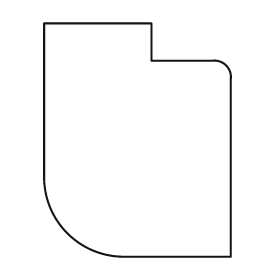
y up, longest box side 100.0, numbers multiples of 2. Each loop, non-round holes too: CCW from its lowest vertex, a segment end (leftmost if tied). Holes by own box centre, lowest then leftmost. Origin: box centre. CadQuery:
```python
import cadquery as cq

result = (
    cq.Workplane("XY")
    .moveTo(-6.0, -50.0)
    .lineTo(40.0, -50.0)
    .lineTo(40.0, 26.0)
    .threePointArc((38.0, 32.0), (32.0, 34.0))
    .lineTo(6.0, 34.0)
    .lineTo(6.0, 50.0)
    .lineTo(-40.0, 50.0)
    .lineTo(-40.0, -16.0)
    .threePointArc((-30.0, -40.0), (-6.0, -50.0))
    .close()
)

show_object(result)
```